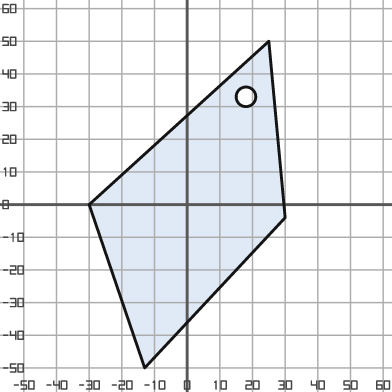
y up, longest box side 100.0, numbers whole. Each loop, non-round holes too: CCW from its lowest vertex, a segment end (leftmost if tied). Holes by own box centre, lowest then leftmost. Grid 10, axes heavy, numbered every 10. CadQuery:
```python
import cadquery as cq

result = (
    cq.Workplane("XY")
    .moveTo(-13.0, -50.0)
    .lineTo(30.0, -4.0)
    .lineTo(25.0, 50.0)
    .lineTo(-30.0, 0.0)
    .close()
    .moveTo(18.0, 33.0)
    .circle(3.0)
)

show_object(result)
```